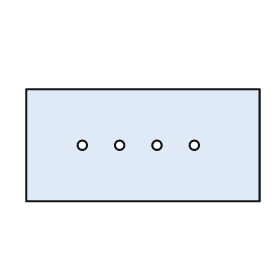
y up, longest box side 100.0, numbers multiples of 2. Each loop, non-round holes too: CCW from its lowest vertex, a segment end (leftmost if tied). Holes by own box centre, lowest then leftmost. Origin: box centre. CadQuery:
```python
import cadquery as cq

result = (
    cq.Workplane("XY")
    .moveTo(-50.0, -24.0)
    .lineTo(50.0, -24.0)
    .lineTo(50.0, 24.0)
    .lineTo(-50.0, 24.0)
    .close()
    .moveTo(-26.0, 0.0)
    .circle(2.0)
    .moveTo(-10.0, 0.0)
    .circle(2.0)
    .moveTo(6.0, 0.0)
    .circle(2.0)
    .moveTo(22.0, 0.0)
    .circle(2.0)
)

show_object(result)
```